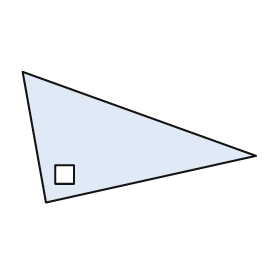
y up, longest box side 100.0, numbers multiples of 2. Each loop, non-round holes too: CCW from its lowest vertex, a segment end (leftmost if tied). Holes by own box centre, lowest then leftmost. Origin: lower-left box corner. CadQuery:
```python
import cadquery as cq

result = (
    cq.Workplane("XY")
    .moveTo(10.0, 0.0)
    .lineTo(100.0, 20.0)
    .lineTo(0.0, 56.0)
    .close()
    .moveTo(14.0, 8.0)
    .lineTo(22.0, 8.0)
    .lineTo(22.0, 16.0)
    .lineTo(14.0, 16.0)
    .close()
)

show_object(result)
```